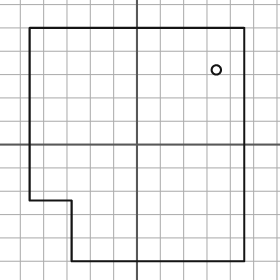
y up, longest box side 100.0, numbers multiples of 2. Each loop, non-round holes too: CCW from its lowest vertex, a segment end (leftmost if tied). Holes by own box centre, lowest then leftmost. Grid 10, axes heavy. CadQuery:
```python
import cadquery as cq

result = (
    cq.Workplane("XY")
    .moveTo(-28.0, -50.0)
    .lineTo(46.0, -50.0)
    .lineTo(46.0, 50.0)
    .lineTo(-46.0, 50.0)
    .lineTo(-46.0, -24.0)
    .lineTo(-28.0, -24.0)
    .close()
    .moveTo(34.0, 32.0)
    .circle(2.0)
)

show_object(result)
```